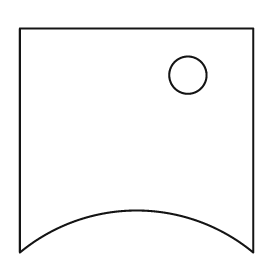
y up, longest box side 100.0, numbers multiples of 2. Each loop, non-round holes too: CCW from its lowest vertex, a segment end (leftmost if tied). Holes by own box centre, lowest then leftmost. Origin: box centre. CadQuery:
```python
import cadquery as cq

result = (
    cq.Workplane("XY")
    .moveTo(-50.0, -48.0)
    .threePointArc((0.0, -30.0), (50.0, -48.0))
    .lineTo(50.0, 48.0)
    .lineTo(-50.0, 48.0)
    .close()
    .moveTo(22.0, 28.0)
    .circle(8.0)
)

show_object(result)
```